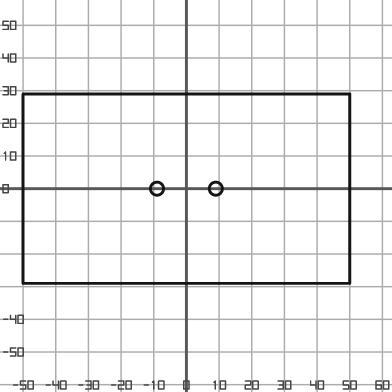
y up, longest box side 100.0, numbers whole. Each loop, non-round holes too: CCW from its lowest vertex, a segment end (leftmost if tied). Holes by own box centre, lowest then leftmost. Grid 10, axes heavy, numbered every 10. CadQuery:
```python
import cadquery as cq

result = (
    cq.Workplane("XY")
    .moveTo(-50.0, -29.0)
    .lineTo(50.0, -29.0)
    .lineTo(50.0, 29.0)
    .lineTo(-50.0, 29.0)
    .close()
    .moveTo(-9.0, 0.0)
    .circle(2.0)
    .moveTo(9.0, 0.0)
    .circle(2.0)
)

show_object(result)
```